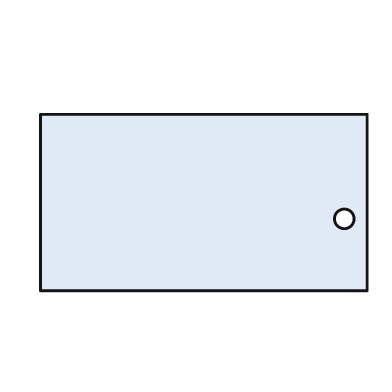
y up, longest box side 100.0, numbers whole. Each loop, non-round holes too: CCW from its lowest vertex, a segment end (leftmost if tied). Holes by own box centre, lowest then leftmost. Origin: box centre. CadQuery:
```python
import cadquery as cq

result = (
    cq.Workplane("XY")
    .moveTo(-50.0, -27.0)
    .lineTo(50.0, -27.0)
    .lineTo(50.0, 27.0)
    .lineTo(-50.0, 27.0)
    .close()
    .moveTo(43.0, -5.0)
    .circle(3.0)
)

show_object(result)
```